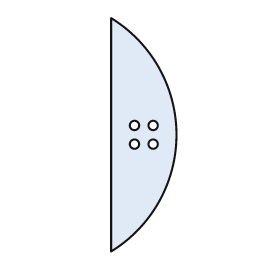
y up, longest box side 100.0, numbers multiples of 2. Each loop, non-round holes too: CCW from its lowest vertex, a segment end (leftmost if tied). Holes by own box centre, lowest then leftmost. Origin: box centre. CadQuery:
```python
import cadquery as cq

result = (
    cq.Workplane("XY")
    .moveTo(-14.0, -50.0)
    .threePointArc((14.0, 0.0), (-14.0, 50.0))
    .close()
    .moveTo(-4.0, -4.0)
    .circle(2.0)
    .moveTo(4.0, -4.0)
    .circle(2.0)
    .moveTo(-4.0, 4.0)
    .circle(2.0)
    .moveTo(4.0, 4.0)
    .circle(2.0)
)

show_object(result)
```